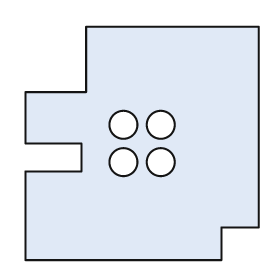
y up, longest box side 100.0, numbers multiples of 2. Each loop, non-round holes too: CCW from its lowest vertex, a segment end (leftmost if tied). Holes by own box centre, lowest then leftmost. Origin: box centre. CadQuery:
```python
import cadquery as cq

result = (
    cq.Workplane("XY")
    .moveTo(-50.0, -50.0)
    .lineTo(34.0, -50.0)
    .lineTo(34.0, -36.0)
    .lineTo(50.0, -36.0)
    .lineTo(50.0, 50.0)
    .lineTo(-24.0, 50.0)
    .lineTo(-24.0, 22.0)
    .lineTo(-50.0, 22.0)
    .lineTo(-50.0, 0.0)
    .lineTo(-26.0, 0.0)
    .lineTo(-26.0, -12.0)
    .lineTo(-50.0, -12.0)
    .close()
    .moveTo(-8.0, -8.0)
    .circle(6.0)
    .moveTo(8.0, -8.0)
    .circle(6.0)
    .moveTo(-8.0, 8.0)
    .circle(6.0)
    .moveTo(8.0, 8.0)
    .circle(6.0)
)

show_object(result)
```